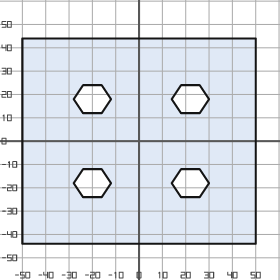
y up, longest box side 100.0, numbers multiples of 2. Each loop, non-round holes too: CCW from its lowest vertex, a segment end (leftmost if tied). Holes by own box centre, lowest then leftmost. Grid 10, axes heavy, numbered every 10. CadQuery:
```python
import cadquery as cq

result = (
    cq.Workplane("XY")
    .moveTo(-50.0, -44.0)
    .lineTo(50.0, -44.0)
    .lineTo(50.0, 44.0)
    .lineTo(-50.0, 44.0)
    .close()
    .moveTo(-24.0, -24.0)
    .lineTo(-16.0, -24.0)
    .lineTo(-12.0, -18.0)
    .lineTo(-16.0, -12.0)
    .lineTo(-24.0, -12.0)
    .lineTo(-28.0, -18.0)
    .close()
    .moveTo(18.0, -24.0)
    .lineTo(26.0, -24.0)
    .lineTo(30.0, -18.0)
    .lineTo(26.0, -12.0)
    .lineTo(18.0, -12.0)
    .lineTo(14.0, -18.0)
    .close()
    .moveTo(-24.0, 12.0)
    .lineTo(-16.0, 12.0)
    .lineTo(-12.0, 18.0)
    .lineTo(-16.0, 24.0)
    .lineTo(-24.0, 24.0)
    .lineTo(-28.0, 18.0)
    .close()
    .moveTo(18.0, 12.0)
    .lineTo(26.0, 12.0)
    .lineTo(30.0, 18.0)
    .lineTo(26.0, 24.0)
    .lineTo(18.0, 24.0)
    .lineTo(14.0, 18.0)
    .close()
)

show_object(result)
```